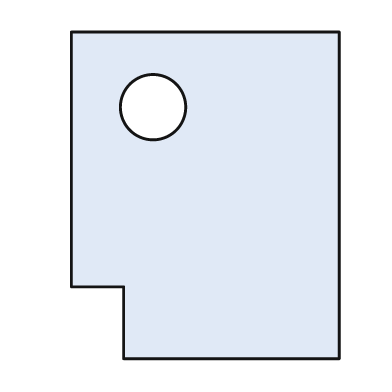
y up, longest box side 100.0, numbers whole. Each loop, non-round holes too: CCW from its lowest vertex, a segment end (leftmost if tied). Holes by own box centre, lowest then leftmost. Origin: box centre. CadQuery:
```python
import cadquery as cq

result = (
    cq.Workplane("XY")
    .moveTo(-25.0, -50.0)
    .lineTo(41.0, -50.0)
    .lineTo(41.0, 50.0)
    .lineTo(-41.0, 50.0)
    .lineTo(-41.0, -28.0)
    .lineTo(-25.0, -28.0)
    .close()
    .moveTo(-16.0, 27.0)
    .circle(10.0)
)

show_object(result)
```